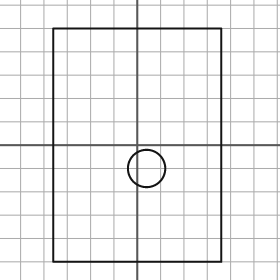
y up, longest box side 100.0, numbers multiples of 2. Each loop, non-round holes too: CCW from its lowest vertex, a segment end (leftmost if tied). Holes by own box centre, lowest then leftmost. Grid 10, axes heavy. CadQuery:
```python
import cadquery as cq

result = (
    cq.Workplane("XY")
    .moveTo(-36.0, -50.0)
    .lineTo(36.0, -50.0)
    .lineTo(36.0, 50.0)
    .lineTo(-36.0, 50.0)
    .close()
    .moveTo(4.0, -10.0)
    .circle(8.0)
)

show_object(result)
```